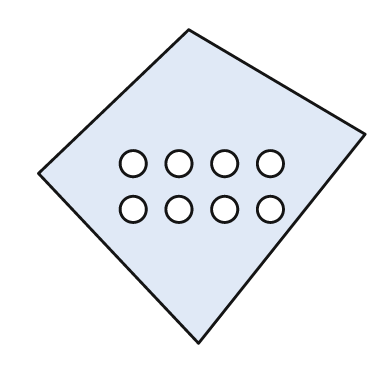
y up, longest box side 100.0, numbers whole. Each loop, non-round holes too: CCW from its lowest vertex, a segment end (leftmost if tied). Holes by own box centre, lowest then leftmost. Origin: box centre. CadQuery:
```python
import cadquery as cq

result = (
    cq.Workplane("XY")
    .moveTo(-1.0, -48.0)
    .lineTo(50.0, 16.0)
    .lineTo(-4.0, 48.0)
    .lineTo(-50.0, 4.0)
    .close()
    .moveTo(-21.0, -7.0)
    .circle(4.0)
    .moveTo(-7.0, -7.0)
    .circle(4.0)
    .moveTo(7.0, -7.0)
    .circle(4.0)
    .moveTo(21.0, -7.0)
    .circle(4.0)
    .moveTo(-21.0, 7.0)
    .circle(4.0)
    .moveTo(-7.0, 7.0)
    .circle(4.0)
    .moveTo(7.0, 7.0)
    .circle(4.0)
    .moveTo(21.0, 7.0)
    .circle(4.0)
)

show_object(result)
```